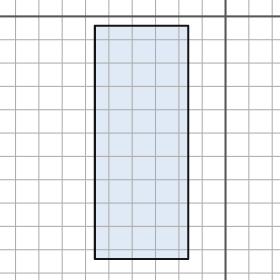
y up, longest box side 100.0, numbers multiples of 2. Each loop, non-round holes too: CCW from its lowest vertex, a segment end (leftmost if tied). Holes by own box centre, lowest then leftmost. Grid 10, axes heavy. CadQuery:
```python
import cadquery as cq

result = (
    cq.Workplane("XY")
    .moveTo(-56.0, -104.0)
    .lineTo(-16.0, -104.0)
    .lineTo(-16.0, -4.0)
    .lineTo(-56.0, -4.0)
    .close()
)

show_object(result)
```